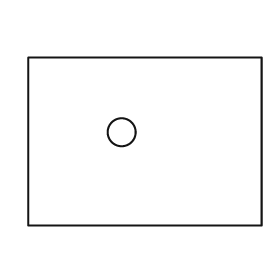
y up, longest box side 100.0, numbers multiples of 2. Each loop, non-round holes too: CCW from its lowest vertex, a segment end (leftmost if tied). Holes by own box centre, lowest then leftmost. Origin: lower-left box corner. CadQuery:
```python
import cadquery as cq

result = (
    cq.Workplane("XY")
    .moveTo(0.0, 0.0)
    .lineTo(100.0, 0.0)
    .lineTo(100.0, 72.0)
    .lineTo(0.0, 72.0)
    .close()
    .moveTo(40.0, 40.0)
    .circle(6.0)
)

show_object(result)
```